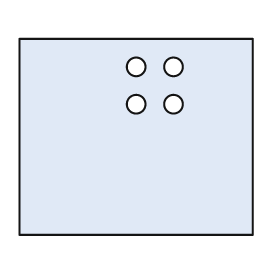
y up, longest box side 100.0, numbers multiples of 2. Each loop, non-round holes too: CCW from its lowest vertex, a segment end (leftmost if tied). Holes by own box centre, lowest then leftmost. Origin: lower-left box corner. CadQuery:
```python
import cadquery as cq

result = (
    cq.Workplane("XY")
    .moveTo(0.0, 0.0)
    .lineTo(100.0, 0.0)
    .lineTo(100.0, 84.0)
    .lineTo(0.0, 84.0)
    .close()
    .moveTo(50.0, 56.0)
    .circle(4.0)
    .moveTo(66.0, 56.0)
    .circle(4.0)
    .moveTo(50.0, 72.0)
    .circle(4.0)
    .moveTo(66.0, 72.0)
    .circle(4.0)
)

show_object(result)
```